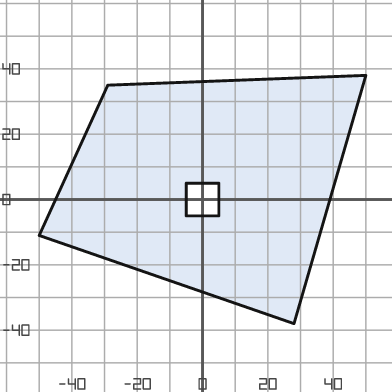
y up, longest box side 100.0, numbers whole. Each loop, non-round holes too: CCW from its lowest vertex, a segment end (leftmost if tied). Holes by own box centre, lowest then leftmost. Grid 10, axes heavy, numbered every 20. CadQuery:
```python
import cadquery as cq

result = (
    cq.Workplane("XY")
    .moveTo(28.0, -38.0)
    .lineTo(50.0, 38.0)
    .lineTo(-29.0, 35.0)
    .lineTo(-50.0, -11.0)
    .close()
    .moveTo(-5.0, -5.0)
    .lineTo(5.0, -5.0)
    .lineTo(5.0, 5.0)
    .lineTo(-5.0, 5.0)
    .close()
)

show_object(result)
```